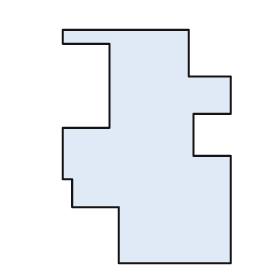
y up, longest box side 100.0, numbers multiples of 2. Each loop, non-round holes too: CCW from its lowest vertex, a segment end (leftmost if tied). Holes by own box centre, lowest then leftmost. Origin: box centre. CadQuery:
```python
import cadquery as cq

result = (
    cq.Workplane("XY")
    .moveTo(-12.0, -50.0)
    .lineTo(36.0, -50.0)
    .lineTo(36.0, -4.0)
    .lineTo(20.0, -4.0)
    .lineTo(20.0, 14.0)
    .lineTo(36.0, 14.0)
    .lineTo(36.0, 30.0)
    .lineTo(18.0, 30.0)
    .lineTo(18.0, 50.0)
    .lineTo(-36.0, 50.0)
    .lineTo(-36.0, 44.0)
    .lineTo(-16.0, 44.0)
    .lineTo(-16.0, 8.0)
    .lineTo(-36.0, 8.0)
    .lineTo(-36.0, -14.0)
    .lineTo(-32.0, -14.0)
    .lineTo(-32.0, -26.0)
    .lineTo(-12.0, -26.0)
    .close()
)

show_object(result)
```